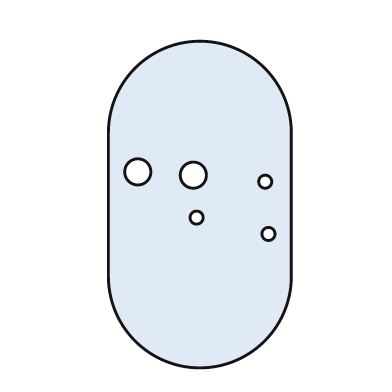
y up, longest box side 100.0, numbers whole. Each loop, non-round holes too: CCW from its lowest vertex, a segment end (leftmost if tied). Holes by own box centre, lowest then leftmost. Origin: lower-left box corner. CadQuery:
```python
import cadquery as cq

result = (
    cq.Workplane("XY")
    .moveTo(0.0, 28.0)
    .threePointArc((28.0, 0.0), (56.0, 28.0))
    .lineTo(56.0, 72.0)
    .threePointArc((28.0, 100.0), (0.0, 72.0))
    .close()
    .moveTo(49.0, 41.0)
    .circle(2.0)
    .moveTo(27.0, 46.0)
    .circle(2.0)
    .moveTo(48.0, 57.0)
    .circle(2.0)
    .moveTo(26.0, 59.0)
    .circle(4.0)
    .moveTo(9.0, 60.0)
    .circle(4.0)
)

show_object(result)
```